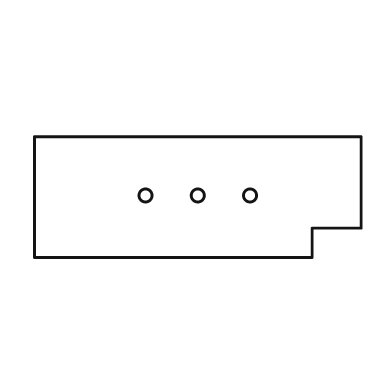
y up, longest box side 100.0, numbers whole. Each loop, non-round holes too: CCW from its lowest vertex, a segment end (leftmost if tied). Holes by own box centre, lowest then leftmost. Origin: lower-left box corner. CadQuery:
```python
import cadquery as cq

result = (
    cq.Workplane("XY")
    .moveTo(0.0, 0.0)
    .lineTo(85.0, 0.0)
    .lineTo(85.0, 9.0)
    .lineTo(100.0, 9.0)
    .lineTo(100.0, 37.0)
    .lineTo(0.0, 37.0)
    .close()
    .moveTo(34.0, 19.0)
    .circle(2.0)
    .moveTo(50.0, 19.0)
    .circle(2.0)
    .moveTo(66.0, 19.0)
    .circle(2.0)
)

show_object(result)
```